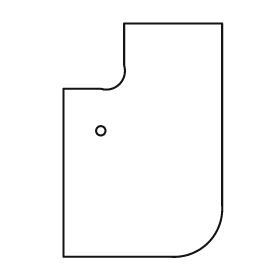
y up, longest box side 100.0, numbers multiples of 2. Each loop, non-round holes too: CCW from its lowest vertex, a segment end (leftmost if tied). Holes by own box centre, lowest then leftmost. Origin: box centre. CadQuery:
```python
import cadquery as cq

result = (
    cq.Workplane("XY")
    .moveTo(-34.0, -50.0)
    .lineTo(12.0, -50.0)
    .threePointArc((28.0, -44.0), (34.0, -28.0))
    .lineTo(34.0, 50.0)
    .lineTo(-8.0, 50.0)
    .lineTo(-8.0, 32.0)
    .threePointArc((-10.0, 24.0), (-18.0, 22.0))
    .lineTo(-34.0, 22.0)
    .close()
    .moveTo(-18.0, 4.0)
    .circle(2.0)
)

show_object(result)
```